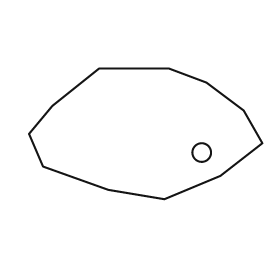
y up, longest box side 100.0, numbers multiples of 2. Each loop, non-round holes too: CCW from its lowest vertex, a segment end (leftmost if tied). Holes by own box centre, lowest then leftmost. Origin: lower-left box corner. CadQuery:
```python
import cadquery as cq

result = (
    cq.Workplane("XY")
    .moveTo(58.0, 0.0)
    .lineTo(82.0, 10.0)
    .lineTo(100.0, 24.0)
    .lineTo(92.0, 38.0)
    .lineTo(76.0, 50.0)
    .lineTo(60.0, 56.0)
    .lineTo(30.0, 56.0)
    .lineTo(10.0, 40.0)
    .lineTo(0.0, 28.0)
    .lineTo(6.0, 14.0)
    .lineTo(34.0, 4.0)
    .close()
    .moveTo(74.0, 20.0)
    .circle(4.0)
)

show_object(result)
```